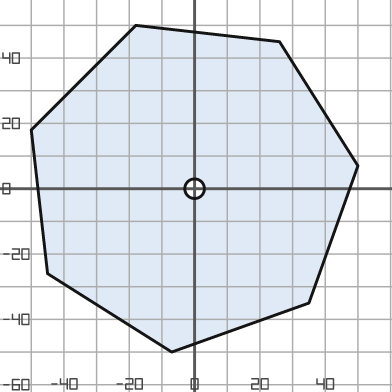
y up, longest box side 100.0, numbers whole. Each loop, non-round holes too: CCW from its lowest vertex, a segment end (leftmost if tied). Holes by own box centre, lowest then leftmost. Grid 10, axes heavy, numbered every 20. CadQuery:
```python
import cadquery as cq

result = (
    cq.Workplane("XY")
    .moveTo(-7.0, -50.0)
    .lineTo(35.0, -35.0)
    .lineTo(50.0, 7.0)
    .lineTo(26.0, 45.0)
    .lineTo(-18.0, 50.0)
    .lineTo(-50.0, 18.0)
    .lineTo(-45.0, -26.0)
    .close()
    .moveTo(0.0, 0.0)
    .circle(3.0)
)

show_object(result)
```